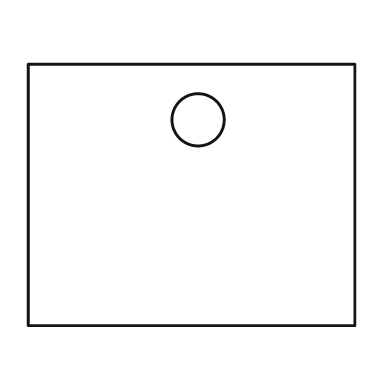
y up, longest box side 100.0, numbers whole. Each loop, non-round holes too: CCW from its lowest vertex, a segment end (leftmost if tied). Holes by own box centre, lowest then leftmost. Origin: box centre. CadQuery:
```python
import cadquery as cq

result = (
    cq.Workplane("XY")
    .moveTo(-50.0, -40.0)
    .lineTo(50.0, -40.0)
    .lineTo(50.0, 40.0)
    .lineTo(-50.0, 40.0)
    .close()
    .moveTo(2.0, 23.0)
    .circle(8.0)
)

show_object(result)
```